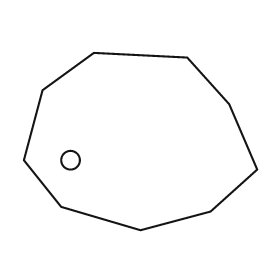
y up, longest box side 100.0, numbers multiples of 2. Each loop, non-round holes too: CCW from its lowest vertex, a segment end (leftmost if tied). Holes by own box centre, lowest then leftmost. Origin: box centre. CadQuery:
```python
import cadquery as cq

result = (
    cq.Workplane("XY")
    .moveTo(0.0, -38.0)
    .lineTo(30.0, -30.0)
    .lineTo(50.0, -12.0)
    .lineTo(38.0, 16.0)
    .lineTo(20.0, 36.0)
    .lineTo(-20.0, 38.0)
    .lineTo(-42.0, 22.0)
    .lineTo(-50.0, -8.0)
    .lineTo(-34.0, -28.0)
    .close()
    .moveTo(-30.0, -8.0)
    .circle(4.0)
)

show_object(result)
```